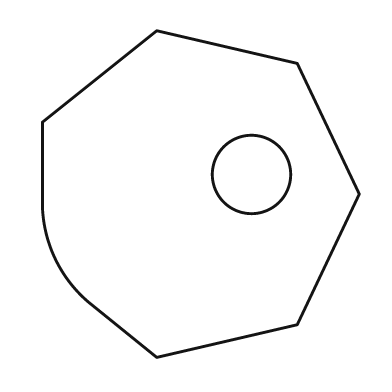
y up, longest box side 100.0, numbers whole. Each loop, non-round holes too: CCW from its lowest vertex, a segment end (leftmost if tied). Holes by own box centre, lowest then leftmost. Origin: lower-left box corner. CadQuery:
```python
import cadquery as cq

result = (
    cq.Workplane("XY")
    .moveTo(35.0, 0.0)
    .lineTo(78.0, 10.0)
    .lineTo(97.0, 50.0)
    .lineTo(78.0, 90.0)
    .lineTo(35.0, 100.0)
    .lineTo(0.0, 72.0)
    .lineTo(0.0, 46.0)
    .threePointArc((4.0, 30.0), (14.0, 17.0))
    .close()
    .moveTo(64.0, 56.0)
    .circle(12.0)
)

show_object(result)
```